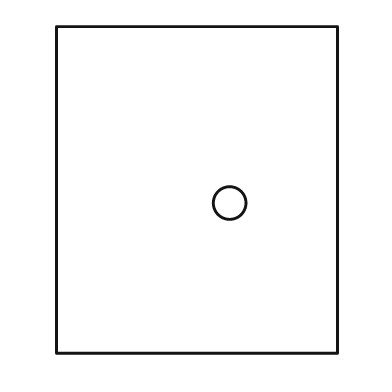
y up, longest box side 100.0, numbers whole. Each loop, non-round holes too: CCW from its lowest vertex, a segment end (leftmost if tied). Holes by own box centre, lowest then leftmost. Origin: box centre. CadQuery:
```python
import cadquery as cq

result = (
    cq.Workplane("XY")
    .moveTo(-43.0, -50.0)
    .lineTo(43.0, -50.0)
    .lineTo(43.0, 50.0)
    .lineTo(-43.0, 50.0)
    .close()
    .moveTo(10.0, -4.0)
    .circle(5.0)
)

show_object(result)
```